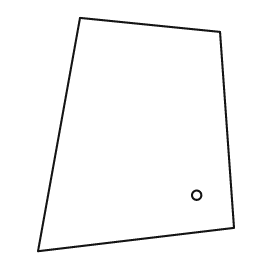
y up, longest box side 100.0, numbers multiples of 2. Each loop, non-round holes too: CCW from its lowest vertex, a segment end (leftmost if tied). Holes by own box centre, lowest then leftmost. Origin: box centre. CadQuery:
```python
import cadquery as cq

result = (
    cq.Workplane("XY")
    .moveTo(-42.0, -50.0)
    .lineTo(42.0, -40.0)
    .lineTo(36.0, 44.0)
    .lineTo(-24.0, 50.0)
    .close()
    .moveTo(26.0, -26.0)
    .circle(2.0)
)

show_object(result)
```